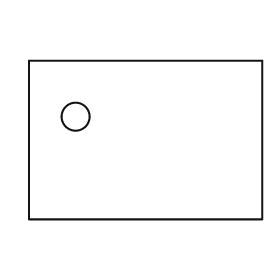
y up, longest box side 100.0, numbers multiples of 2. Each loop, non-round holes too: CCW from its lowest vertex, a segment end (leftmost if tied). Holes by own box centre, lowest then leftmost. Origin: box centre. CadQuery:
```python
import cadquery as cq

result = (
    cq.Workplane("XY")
    .moveTo(-50.0, -34.0)
    .lineTo(50.0, -34.0)
    .lineTo(50.0, 34.0)
    .lineTo(-50.0, 34.0)
    .close()
    .moveTo(-30.0, 10.0)
    .circle(6.0)
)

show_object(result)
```